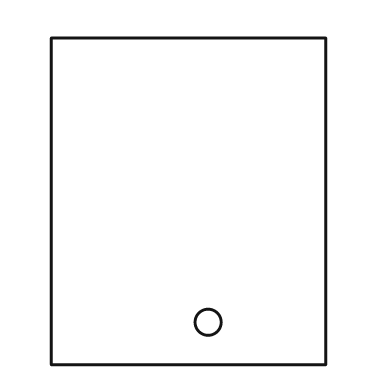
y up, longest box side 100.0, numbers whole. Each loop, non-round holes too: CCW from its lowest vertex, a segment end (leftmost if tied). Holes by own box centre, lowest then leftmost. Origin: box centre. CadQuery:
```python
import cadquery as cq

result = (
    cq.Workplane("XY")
    .moveTo(-42.0, -50.0)
    .lineTo(42.0, -50.0)
    .lineTo(42.0, 50.0)
    .lineTo(-42.0, 50.0)
    .close()
    .moveTo(6.0, -37.0)
    .circle(4.0)
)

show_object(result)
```